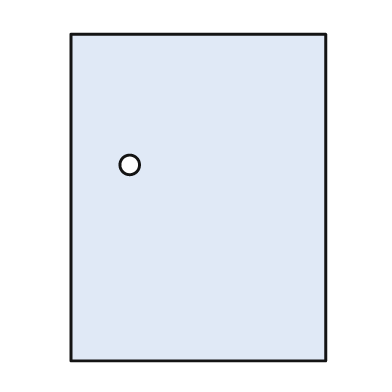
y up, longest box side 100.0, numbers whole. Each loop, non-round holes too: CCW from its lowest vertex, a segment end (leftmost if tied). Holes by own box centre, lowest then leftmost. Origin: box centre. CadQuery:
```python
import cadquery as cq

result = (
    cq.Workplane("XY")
    .moveTo(-39.0, -50.0)
    .lineTo(39.0, -50.0)
    .lineTo(39.0, 50.0)
    .lineTo(-39.0, 50.0)
    .close()
    .moveTo(-21.0, 10.0)
    .circle(3.0)
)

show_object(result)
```